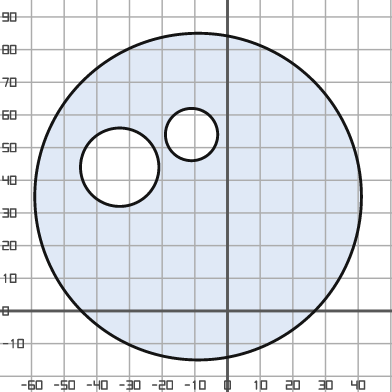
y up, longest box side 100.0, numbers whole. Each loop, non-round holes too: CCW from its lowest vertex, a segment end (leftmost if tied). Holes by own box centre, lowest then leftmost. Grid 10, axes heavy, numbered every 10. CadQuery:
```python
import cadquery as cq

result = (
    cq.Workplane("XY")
    .moveTo(-9.0, 35.0)
    .circle(50.0)
    .moveTo(-33.0, 44.0)
    .circle(12.0)
    .moveTo(-11.0, 54.0)
    .circle(8.0)
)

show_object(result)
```